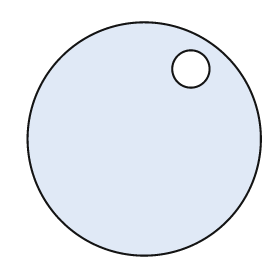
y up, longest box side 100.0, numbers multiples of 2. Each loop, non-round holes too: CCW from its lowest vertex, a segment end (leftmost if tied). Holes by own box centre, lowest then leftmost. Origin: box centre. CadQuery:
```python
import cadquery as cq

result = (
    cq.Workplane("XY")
    .moveTo(0.0, 0.0)
    .circle(50.0)
    .moveTo(20.0, 30.0)
    .circle(8.0)
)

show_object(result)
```